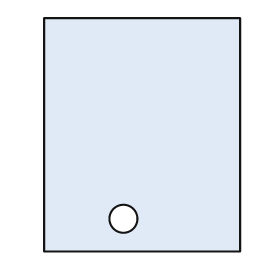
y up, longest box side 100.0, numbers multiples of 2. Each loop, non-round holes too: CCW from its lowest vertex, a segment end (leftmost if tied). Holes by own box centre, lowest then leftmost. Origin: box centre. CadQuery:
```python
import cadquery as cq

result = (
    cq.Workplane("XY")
    .moveTo(-42.0, -50.0)
    .lineTo(42.0, -50.0)
    .lineTo(42.0, 50.0)
    .lineTo(-42.0, 50.0)
    .close()
    .moveTo(-8.0, -36.0)
    .circle(6.0)
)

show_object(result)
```